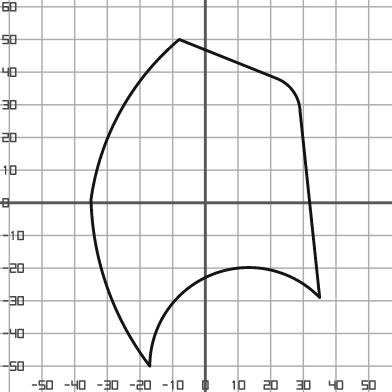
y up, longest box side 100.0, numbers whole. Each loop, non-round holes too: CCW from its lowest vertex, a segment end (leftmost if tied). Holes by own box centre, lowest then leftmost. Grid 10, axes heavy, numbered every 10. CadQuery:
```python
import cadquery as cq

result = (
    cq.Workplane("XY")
    .moveTo(-17.0, -50.0)
    .threePointArc((2.0, -22.0), (35.0, -29.0))
    .lineTo(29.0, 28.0)
    .threePointArc((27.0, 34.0), (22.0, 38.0))
    .lineTo(-8.0, 50.0)
    .threePointArc((-26.0, 28.0), (-35.0, 1.0))
    .threePointArc((-30.0, -26.0), (-17.0, -50.0))
    .close()
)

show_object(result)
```